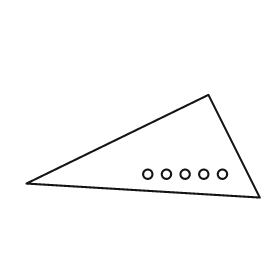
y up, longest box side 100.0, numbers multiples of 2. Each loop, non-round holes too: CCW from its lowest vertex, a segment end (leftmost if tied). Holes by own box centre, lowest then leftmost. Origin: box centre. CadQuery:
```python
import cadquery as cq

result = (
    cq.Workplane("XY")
    .moveTo(50.0, -22.0)
    .lineTo(28.0, 22.0)
    .lineTo(-50.0, -16.0)
    .close()
    .moveTo(2.0, -12.0)
    .circle(2.0)
    .moveTo(10.0, -12.0)
    .circle(2.0)
    .moveTo(18.0, -12.0)
    .circle(2.0)
    .moveTo(26.0, -12.0)
    .circle(2.0)
    .moveTo(34.0, -12.0)
    .circle(2.0)
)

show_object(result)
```